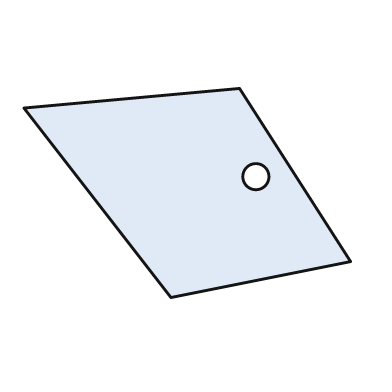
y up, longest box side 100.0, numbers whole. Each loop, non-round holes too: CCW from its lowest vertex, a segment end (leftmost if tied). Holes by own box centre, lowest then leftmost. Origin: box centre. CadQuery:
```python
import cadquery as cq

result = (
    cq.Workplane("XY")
    .moveTo(-5.0, -32.0)
    .lineTo(50.0, -21.0)
    .lineTo(16.0, 32.0)
    .lineTo(-50.0, 26.0)
    .close()
    .moveTo(21.0, 5.0)
    .circle(4.0)
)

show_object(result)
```